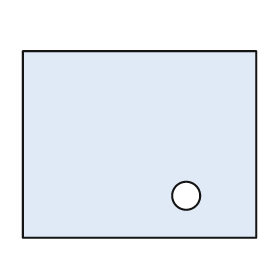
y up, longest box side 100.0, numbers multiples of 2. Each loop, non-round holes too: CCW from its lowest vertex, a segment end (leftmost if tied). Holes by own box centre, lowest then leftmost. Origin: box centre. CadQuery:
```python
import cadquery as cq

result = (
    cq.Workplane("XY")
    .moveTo(-50.0, -40.0)
    .lineTo(50.0, -40.0)
    .lineTo(50.0, 40.0)
    .lineTo(-50.0, 40.0)
    .close()
    .moveTo(20.0, -22.0)
    .circle(6.0)
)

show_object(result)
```